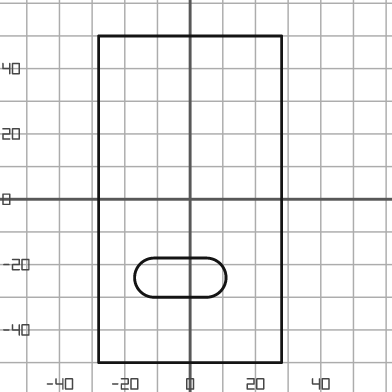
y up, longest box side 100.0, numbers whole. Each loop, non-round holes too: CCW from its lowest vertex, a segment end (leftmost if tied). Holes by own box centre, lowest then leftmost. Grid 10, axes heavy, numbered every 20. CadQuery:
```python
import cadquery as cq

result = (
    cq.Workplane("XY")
    .moveTo(-28.0, -50.0)
    .lineTo(28.0, -50.0)
    .lineTo(28.0, 50.0)
    .lineTo(-28.0, 50.0)
    .close()
    .moveTo(-11.0, -30.0)
    .lineTo(5.0, -30.0)
    .threePointArc((11.0, -24.0), (5.0, -18.0))
    .lineTo(-11.0, -18.0)
    .threePointArc((-17.0, -24.0), (-11.0, -30.0))
    .close()
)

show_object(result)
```